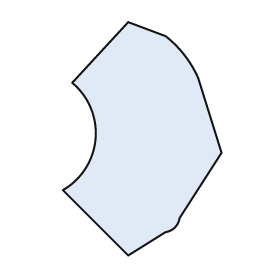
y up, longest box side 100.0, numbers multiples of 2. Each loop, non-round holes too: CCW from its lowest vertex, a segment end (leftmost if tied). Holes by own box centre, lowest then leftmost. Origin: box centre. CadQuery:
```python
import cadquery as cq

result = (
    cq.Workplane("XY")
    .moveTo(-6.0, -50.0)
    .lineTo(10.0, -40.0)
    .threePointArc((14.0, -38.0), (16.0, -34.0))
    .lineTo(34.0, -6.0)
    .lineTo(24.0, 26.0)
    .threePointArc((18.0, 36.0), (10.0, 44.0))
    .lineTo(-6.0, 50.0)
    .lineTo(-30.0, 24.0)
    .threePointArc((-20.0, 0.0), (-34.0, -22.0))
    .close()
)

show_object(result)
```